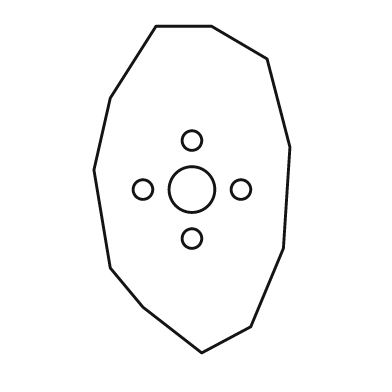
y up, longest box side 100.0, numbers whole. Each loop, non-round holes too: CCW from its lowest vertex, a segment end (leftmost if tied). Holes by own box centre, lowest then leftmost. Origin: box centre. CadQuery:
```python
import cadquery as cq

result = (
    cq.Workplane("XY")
    .moveTo(3.0, -50.0)
    .lineTo(18.0, -42.0)
    .lineTo(28.0, -18.0)
    .lineTo(30.0, 13.0)
    .lineTo(23.0, 40.0)
    .lineTo(6.0, 50.0)
    .lineTo(-11.0, 50.0)
    .lineTo(-25.0, 28.0)
    .lineTo(-30.0, 6.0)
    .lineTo(-25.0, -24.0)
    .lineTo(-15.0, -36.0)
    .close()
    .moveTo(0.0, -15.0)
    .circle(3.0)
    .moveTo(-15.0, 0.0)
    .circle(3.0)
    .moveTo(0.0, 0.0)
    .circle(7.0)
    .moveTo(15.0, 0.0)
    .circle(3.0)
    .moveTo(0.0, 15.0)
    .circle(3.0)
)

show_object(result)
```